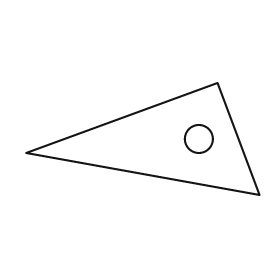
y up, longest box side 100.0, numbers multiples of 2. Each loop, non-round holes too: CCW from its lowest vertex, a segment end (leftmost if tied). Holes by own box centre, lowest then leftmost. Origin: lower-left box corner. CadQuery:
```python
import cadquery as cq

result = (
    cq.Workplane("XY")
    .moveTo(100.0, 0.0)
    .lineTo(82.0, 48.0)
    .lineTo(0.0, 18.0)
    .close()
    .moveTo(74.0, 24.0)
    .circle(6.0)
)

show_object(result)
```